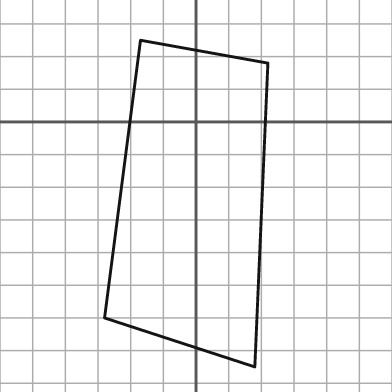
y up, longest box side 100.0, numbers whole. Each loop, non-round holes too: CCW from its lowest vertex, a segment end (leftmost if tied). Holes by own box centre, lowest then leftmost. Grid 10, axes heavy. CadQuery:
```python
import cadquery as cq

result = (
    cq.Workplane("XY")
    .moveTo(18.0, -75.0)
    .lineTo(22.0, 18.0)
    .lineTo(-17.0, 25.0)
    .lineTo(-28.0, -60.0)
    .close()
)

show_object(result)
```